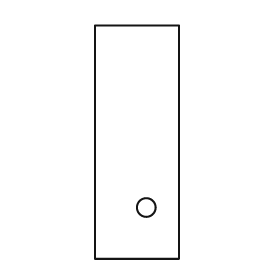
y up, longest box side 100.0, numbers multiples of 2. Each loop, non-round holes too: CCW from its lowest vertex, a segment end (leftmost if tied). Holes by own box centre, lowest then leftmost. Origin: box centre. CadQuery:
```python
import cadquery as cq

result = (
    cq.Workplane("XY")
    .moveTo(-18.0, -50.0)
    .lineTo(18.0, -50.0)
    .lineTo(18.0, 50.0)
    .lineTo(-18.0, 50.0)
    .close()
    .moveTo(4.0, -28.0)
    .circle(4.0)
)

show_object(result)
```